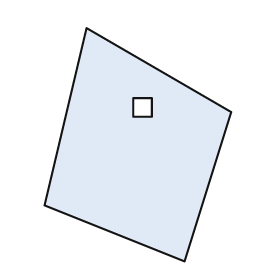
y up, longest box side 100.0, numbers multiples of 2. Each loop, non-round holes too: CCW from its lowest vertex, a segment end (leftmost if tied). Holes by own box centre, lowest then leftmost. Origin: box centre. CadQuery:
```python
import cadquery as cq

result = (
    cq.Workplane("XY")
    .moveTo(20.0, -50.0)
    .lineTo(40.0, 14.0)
    .lineTo(-22.0, 50.0)
    .lineTo(-40.0, -26.0)
    .close()
    .moveTo(-2.0, 12.0)
    .lineTo(6.0, 12.0)
    .lineTo(6.0, 20.0)
    .lineTo(-2.0, 20.0)
    .close()
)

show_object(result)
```